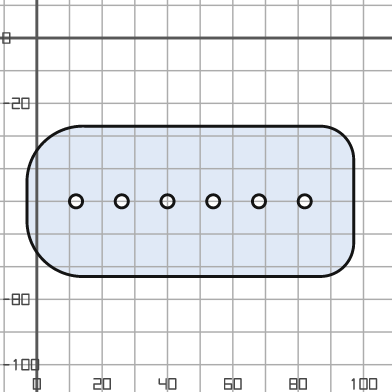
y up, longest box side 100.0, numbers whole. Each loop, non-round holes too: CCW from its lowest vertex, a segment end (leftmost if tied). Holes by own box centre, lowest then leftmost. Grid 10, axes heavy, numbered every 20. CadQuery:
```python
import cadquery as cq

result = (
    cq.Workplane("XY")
    .moveTo(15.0, -73.0)
    .lineTo(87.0, -73.0)
    .threePointArc((94.0, -70.0), (97.0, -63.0))
    .lineTo(97.0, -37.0)
    .threePointArc((94.0, -30.0), (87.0, -27.0))
    .lineTo(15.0, -27.0)
    .threePointArc((2.0, -32.0), (-3.0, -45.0))
    .lineTo(-3.0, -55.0)
    .threePointArc((2.0, -68.0), (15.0, -73.0))
    .close()
    .moveTo(12.0, -50.0)
    .circle(2.0)
    .moveTo(26.0, -50.0)
    .circle(2.0)
    .moveTo(40.0, -50.0)
    .circle(2.0)
    .moveTo(54.0, -50.0)
    .circle(2.0)
    .moveTo(68.0, -50.0)
    .circle(2.0)
    .moveTo(82.0, -50.0)
    .circle(2.0)
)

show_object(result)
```